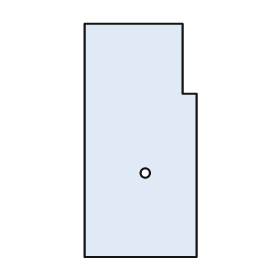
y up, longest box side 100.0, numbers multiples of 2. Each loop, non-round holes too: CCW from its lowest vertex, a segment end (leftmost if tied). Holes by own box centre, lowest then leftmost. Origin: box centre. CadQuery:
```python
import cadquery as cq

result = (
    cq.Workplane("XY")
    .moveTo(-24.0, -50.0)
    .lineTo(24.0, -50.0)
    .lineTo(24.0, 20.0)
    .lineTo(18.0, 20.0)
    .lineTo(18.0, 50.0)
    .lineTo(-24.0, 50.0)
    .close()
    .moveTo(2.0, -14.0)
    .circle(2.0)
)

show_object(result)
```